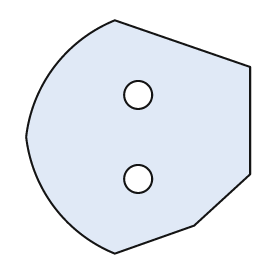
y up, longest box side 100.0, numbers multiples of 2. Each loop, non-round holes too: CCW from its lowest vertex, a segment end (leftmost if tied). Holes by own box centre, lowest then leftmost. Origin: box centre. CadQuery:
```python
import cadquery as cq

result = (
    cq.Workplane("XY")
    .moveTo(-10.0, -50.0)
    .lineTo(24.0, -38.0)
    .lineTo(48.0, -16.0)
    .lineTo(48.0, 30.0)
    .lineTo(-10.0, 50.0)
    .threePointArc((-36.0, 30.0), (-48.0, 0.0))
    .threePointArc((-36.0, -30.0), (-10.0, -50.0))
    .close()
    .moveTo(0.0, -18.0)
    .circle(6.0)
    .moveTo(0.0, 18.0)
    .circle(6.0)
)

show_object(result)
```